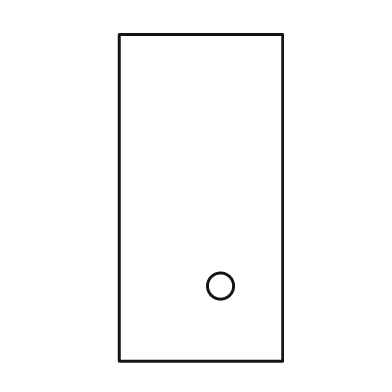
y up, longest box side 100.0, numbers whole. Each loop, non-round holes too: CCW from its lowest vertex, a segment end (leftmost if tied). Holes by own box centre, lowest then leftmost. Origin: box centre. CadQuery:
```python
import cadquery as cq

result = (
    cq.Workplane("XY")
    .moveTo(-25.0, -50.0)
    .lineTo(25.0, -50.0)
    .lineTo(25.0, 50.0)
    .lineTo(-25.0, 50.0)
    .close()
    .moveTo(6.0, -27.0)
    .circle(4.0)
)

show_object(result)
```